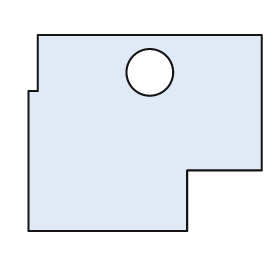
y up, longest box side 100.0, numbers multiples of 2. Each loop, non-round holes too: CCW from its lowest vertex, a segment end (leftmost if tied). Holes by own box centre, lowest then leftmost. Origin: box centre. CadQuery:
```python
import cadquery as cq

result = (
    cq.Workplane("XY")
    .moveTo(-50.0, -42.0)
    .lineTo(18.0, -42.0)
    .lineTo(18.0, -16.0)
    .lineTo(50.0, -16.0)
    .lineTo(50.0, 42.0)
    .lineTo(-46.0, 42.0)
    .lineTo(-46.0, 18.0)
    .lineTo(-50.0, 18.0)
    .close()
    .moveTo(2.0, 26.0)
    .circle(10.0)
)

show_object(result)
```